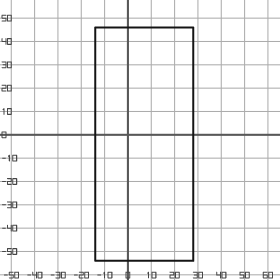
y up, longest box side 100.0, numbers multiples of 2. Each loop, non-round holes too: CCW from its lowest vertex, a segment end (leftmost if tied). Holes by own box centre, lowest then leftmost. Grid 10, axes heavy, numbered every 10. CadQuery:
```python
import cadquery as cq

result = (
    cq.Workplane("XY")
    .moveTo(-14.0, -54.0)
    .lineTo(28.0, -54.0)
    .lineTo(28.0, 46.0)
    .lineTo(-14.0, 46.0)
    .close()
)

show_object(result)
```